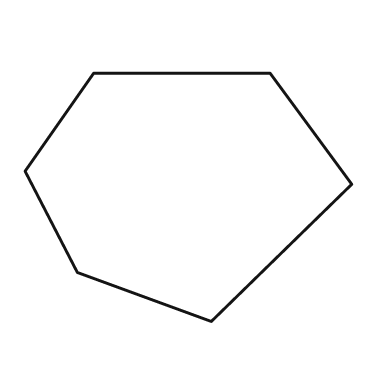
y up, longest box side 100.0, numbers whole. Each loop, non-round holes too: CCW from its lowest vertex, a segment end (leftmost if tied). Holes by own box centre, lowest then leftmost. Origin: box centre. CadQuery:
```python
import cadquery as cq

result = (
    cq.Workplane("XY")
    .moveTo(7.0, -38.0)
    .lineTo(50.0, 4.0)
    .lineTo(25.0, 38.0)
    .lineTo(-29.0, 38.0)
    .lineTo(-50.0, 8.0)
    .lineTo(-34.0, -23.0)
    .close()
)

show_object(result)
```